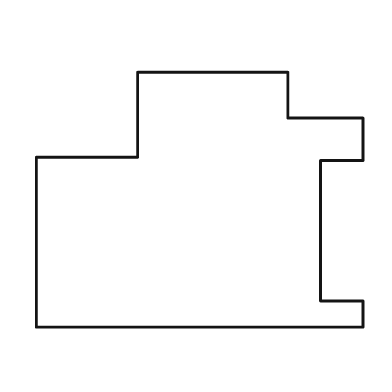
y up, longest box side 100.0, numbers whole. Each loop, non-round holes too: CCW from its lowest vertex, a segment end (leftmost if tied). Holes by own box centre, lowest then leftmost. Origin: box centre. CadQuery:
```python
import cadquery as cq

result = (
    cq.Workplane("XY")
    .moveTo(-50.0, -39.0)
    .lineTo(50.0, -39.0)
    .lineTo(50.0, -31.0)
    .lineTo(37.0, -31.0)
    .lineTo(37.0, 12.0)
    .lineTo(50.0, 12.0)
    .lineTo(50.0, 25.0)
    .lineTo(27.0, 25.0)
    .lineTo(27.0, 39.0)
    .lineTo(-19.0, 39.0)
    .lineTo(-19.0, 13.0)
    .lineTo(-50.0, 13.0)
    .close()
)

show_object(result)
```